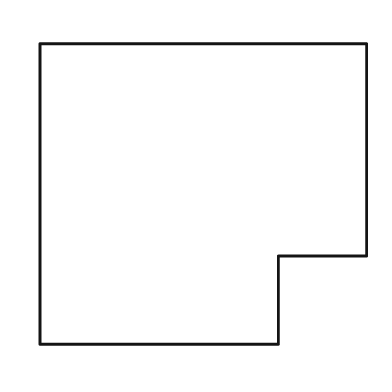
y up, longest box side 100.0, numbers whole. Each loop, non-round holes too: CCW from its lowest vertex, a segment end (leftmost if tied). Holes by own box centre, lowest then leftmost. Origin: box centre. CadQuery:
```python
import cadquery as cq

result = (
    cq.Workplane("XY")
    .moveTo(-50.0, -46.0)
    .lineTo(23.0, -46.0)
    .lineTo(23.0, -19.0)
    .lineTo(50.0, -19.0)
    .lineTo(50.0, 46.0)
    .lineTo(-50.0, 46.0)
    .close()
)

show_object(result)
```